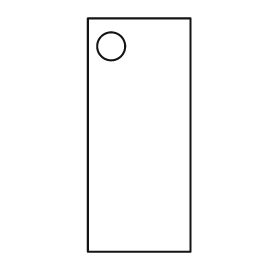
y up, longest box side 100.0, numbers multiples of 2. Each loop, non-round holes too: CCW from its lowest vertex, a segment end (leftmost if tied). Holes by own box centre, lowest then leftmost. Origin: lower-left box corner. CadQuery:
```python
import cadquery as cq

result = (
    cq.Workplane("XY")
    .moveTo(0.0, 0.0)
    .lineTo(44.0, 0.0)
    .lineTo(44.0, 100.0)
    .lineTo(0.0, 100.0)
    .close()
    .moveTo(10.0, 88.0)
    .circle(6.0)
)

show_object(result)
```